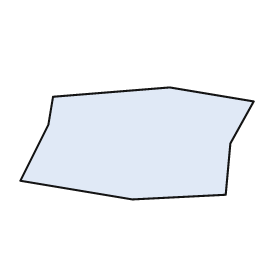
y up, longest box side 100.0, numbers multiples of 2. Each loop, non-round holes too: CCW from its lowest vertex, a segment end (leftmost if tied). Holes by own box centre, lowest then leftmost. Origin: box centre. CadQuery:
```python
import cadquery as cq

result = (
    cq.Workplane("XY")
    .moveTo(-2.0, -24.0)
    .lineTo(38.0, -22.0)
    .lineTo(40.0, 0.0)
    .lineTo(50.0, 18.0)
    .lineTo(14.0, 24.0)
    .lineTo(-36.0, 20.0)
    .lineTo(-38.0, 8.0)
    .lineTo(-50.0, -16.0)
    .close()
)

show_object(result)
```